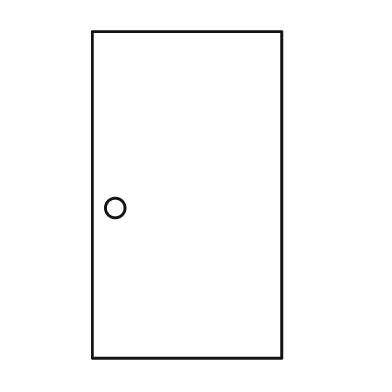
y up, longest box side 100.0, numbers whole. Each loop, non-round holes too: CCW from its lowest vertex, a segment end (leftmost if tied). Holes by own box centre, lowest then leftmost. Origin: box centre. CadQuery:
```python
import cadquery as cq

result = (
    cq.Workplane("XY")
    .moveTo(-29.0, -50.0)
    .lineTo(29.0, -50.0)
    .lineTo(29.0, 50.0)
    .lineTo(-29.0, 50.0)
    .close()
    .moveTo(-22.0, -4.0)
    .circle(3.0)
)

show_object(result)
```